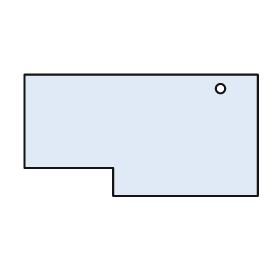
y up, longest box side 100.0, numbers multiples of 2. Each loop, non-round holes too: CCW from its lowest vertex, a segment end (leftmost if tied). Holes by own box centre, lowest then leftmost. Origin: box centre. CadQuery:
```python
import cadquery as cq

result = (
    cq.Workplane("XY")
    .moveTo(-12.0, -26.0)
    .lineTo(50.0, -26.0)
    .lineTo(50.0, 26.0)
    .lineTo(-50.0, 26.0)
    .lineTo(-50.0, -14.0)
    .lineTo(-12.0, -14.0)
    .close()
    .moveTo(34.0, 20.0)
    .circle(2.0)
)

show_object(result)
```